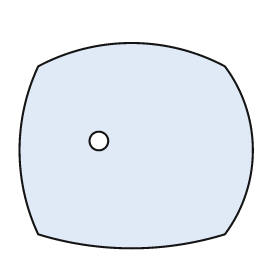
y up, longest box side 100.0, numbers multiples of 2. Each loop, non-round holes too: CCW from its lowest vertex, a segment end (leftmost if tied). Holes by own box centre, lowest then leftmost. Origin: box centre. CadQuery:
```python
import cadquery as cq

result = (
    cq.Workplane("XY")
    .moveTo(-42.0, -38.0)
    .threePointArc((-2.0, -44.0), (38.0, -38.0))
    .threePointArc((50.0, -2.0), (38.0, 34.0))
    .threePointArc((-2.0, 44.0), (-42.0, 34.0))
    .threePointArc((-50.0, -2.0), (-42.0, -38.0))
    .close()
    .moveTo(-16.0, 2.0)
    .circle(4.0)
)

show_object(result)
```